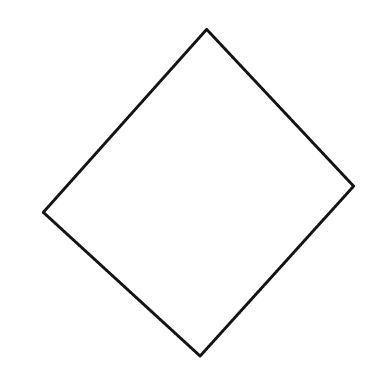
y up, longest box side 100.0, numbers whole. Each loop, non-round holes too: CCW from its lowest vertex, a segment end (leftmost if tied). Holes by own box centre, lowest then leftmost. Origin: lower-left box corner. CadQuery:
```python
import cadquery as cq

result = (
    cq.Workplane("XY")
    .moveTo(48.0, 0.0)
    .lineTo(95.0, 52.0)
    .lineTo(50.0, 100.0)
    .lineTo(0.0, 44.0)
    .close()
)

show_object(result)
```